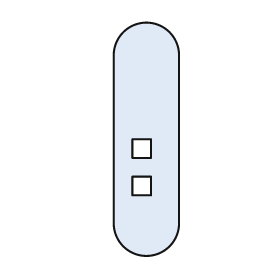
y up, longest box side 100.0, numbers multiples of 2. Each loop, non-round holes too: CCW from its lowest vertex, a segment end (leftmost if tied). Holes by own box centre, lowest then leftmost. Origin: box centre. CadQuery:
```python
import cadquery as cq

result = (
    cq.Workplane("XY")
    .moveTo(-14.0, -36.0)
    .threePointArc((0.0, -50.0), (14.0, -36.0))
    .lineTo(14.0, 36.0)
    .threePointArc((0.0, 50.0), (-14.0, 36.0))
    .close()
    .moveTo(-6.0, -24.0)
    .lineTo(2.0, -24.0)
    .lineTo(2.0, -16.0)
    .lineTo(-6.0, -16.0)
    .close()
    .moveTo(-6.0, -8.0)
    .lineTo(2.0, -8.0)
    .lineTo(2.0, 0.0)
    .lineTo(-6.0, 0.0)
    .close()
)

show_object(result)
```